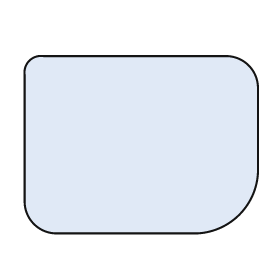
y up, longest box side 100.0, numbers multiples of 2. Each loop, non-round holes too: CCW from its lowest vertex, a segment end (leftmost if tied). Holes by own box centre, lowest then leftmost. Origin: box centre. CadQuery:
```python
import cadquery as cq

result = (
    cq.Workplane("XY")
    .moveTo(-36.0, -38.0)
    .lineTo(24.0, -38.0)
    .threePointArc((42.0, -30.0), (50.0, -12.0))
    .lineTo(50.0, 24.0)
    .threePointArc((46.0, 34.0), (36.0, 38.0))
    .lineTo(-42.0, 38.0)
    .threePointArc((-48.0, 36.0), (-50.0, 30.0))
    .lineTo(-50.0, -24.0)
    .threePointArc((-46.0, -34.0), (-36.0, -38.0))
    .close()
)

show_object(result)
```